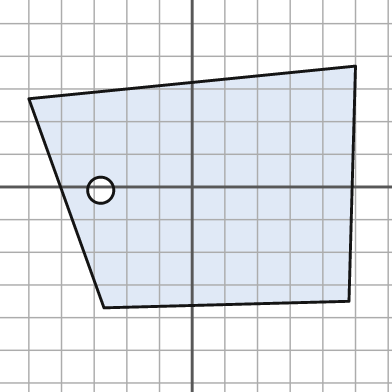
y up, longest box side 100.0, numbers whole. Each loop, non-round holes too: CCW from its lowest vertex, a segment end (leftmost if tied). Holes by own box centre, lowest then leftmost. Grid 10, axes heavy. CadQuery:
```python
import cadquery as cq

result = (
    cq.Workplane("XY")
    .moveTo(-27.0, -37.0)
    .lineTo(48.0, -35.0)
    .lineTo(50.0, 37.0)
    .lineTo(-50.0, 27.0)
    .close()
    .moveTo(-28.0, -1.0)
    .circle(4.0)
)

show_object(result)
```